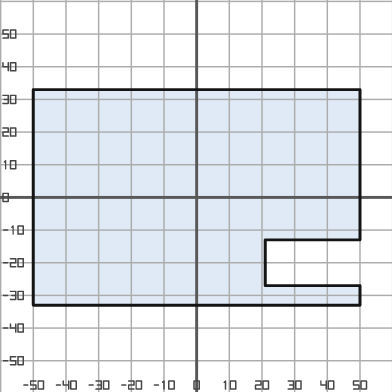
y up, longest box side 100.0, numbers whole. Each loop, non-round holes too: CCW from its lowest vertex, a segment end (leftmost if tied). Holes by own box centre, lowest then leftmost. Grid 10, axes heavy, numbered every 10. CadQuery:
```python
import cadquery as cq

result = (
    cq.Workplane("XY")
    .moveTo(-50.0, -33.0)
    .lineTo(50.0, -33.0)
    .lineTo(50.0, -27.0)
    .lineTo(21.0, -27.0)
    .lineTo(21.0, -13.0)
    .lineTo(50.0, -13.0)
    .lineTo(50.0, 33.0)
    .lineTo(-50.0, 33.0)
    .close()
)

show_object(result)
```